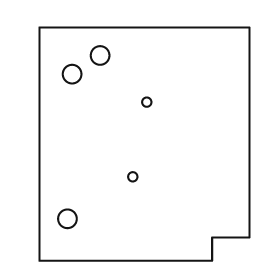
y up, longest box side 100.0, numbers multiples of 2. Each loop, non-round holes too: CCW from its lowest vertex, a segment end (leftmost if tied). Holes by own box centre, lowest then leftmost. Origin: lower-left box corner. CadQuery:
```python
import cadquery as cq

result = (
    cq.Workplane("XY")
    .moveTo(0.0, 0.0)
    .lineTo(74.0, 0.0)
    .lineTo(74.0, 10.0)
    .lineTo(90.0, 10.0)
    .lineTo(90.0, 100.0)
    .lineTo(0.0, 100.0)
    .close()
    .moveTo(12.0, 18.0)
    .circle(4.0)
    .moveTo(40.0, 36.0)
    .circle(2.0)
    .moveTo(46.0, 68.0)
    .circle(2.0)
    .moveTo(14.0, 80.0)
    .circle(4.0)
    .moveTo(26.0, 88.0)
    .circle(4.0)
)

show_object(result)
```